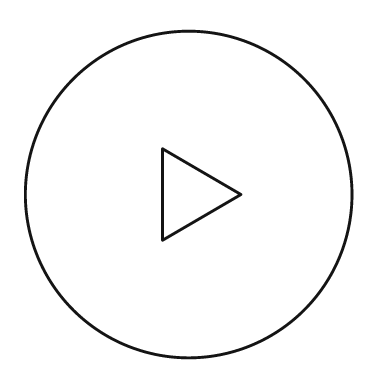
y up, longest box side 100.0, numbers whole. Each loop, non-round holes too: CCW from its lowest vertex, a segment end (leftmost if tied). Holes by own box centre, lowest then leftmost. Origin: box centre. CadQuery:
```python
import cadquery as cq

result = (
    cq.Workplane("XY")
    .moveTo(0.0, 0.0)
    .circle(50.0)
    .moveTo(-8.0, -14.0)
    .lineTo(16.0, 0.0)
    .lineTo(-8.0, 14.0)
    .close()
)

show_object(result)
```